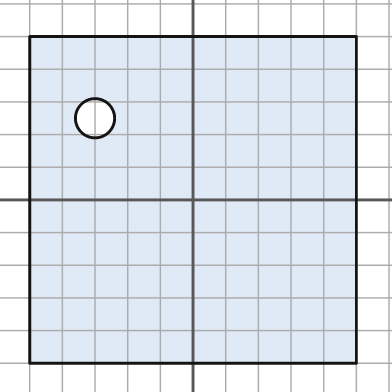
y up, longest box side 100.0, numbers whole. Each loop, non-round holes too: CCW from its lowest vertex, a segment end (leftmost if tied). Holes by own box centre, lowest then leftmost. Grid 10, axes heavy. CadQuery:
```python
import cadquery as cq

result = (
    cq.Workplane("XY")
    .moveTo(-50.0, -50.0)
    .lineTo(50.0, -50.0)
    .lineTo(50.0, 50.0)
    .lineTo(-50.0, 50.0)
    .close()
    .moveTo(-30.0, 25.0)
    .circle(6.0)
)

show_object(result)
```